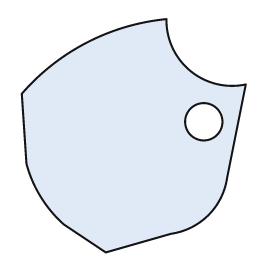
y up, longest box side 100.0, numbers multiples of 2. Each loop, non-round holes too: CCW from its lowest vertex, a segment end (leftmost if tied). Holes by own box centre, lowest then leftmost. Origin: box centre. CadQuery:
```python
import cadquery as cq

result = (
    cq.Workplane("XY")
    .moveTo(-12.0, -50.0)
    .lineTo(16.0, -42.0)
    .threePointArc((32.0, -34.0), (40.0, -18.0))
    .lineTo(48.0, 22.0)
    .threePointArc((24.0, 28.0), (14.0, 50.0))
    .threePointArc((-20.0, 40.0), (-48.0, 18.0))
    .lineTo(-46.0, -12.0)
    .threePointArc((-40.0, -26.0), (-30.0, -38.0))
    .close()
    .moveTo(30.0, 6.0)
    .circle(8.0)
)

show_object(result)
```